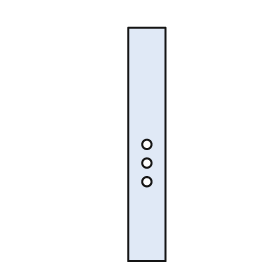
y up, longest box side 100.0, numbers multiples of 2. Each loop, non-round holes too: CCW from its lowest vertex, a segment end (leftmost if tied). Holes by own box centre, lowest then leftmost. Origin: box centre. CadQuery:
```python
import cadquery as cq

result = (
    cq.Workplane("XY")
    .moveTo(-8.0, -50.0)
    .lineTo(8.0, -50.0)
    .lineTo(8.0, 50.0)
    .lineTo(-8.0, 50.0)
    .close()
    .moveTo(0.0, -16.0)
    .circle(2.0)
    .moveTo(0.0, -8.0)
    .circle(2.0)
    .moveTo(0.0, 0.0)
    .circle(2.0)
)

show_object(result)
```